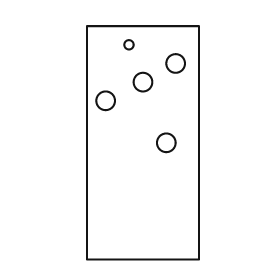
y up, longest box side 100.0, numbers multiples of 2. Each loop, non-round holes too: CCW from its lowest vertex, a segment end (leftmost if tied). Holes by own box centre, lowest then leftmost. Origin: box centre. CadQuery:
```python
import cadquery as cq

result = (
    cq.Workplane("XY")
    .moveTo(-24.0, -50.0)
    .lineTo(24.0, -50.0)
    .lineTo(24.0, 50.0)
    .lineTo(-24.0, 50.0)
    .close()
    .moveTo(10.0, 0.0)
    .circle(4.0)
    .moveTo(-16.0, 18.0)
    .circle(4.0)
    .moveTo(0.0, 26.0)
    .circle(4.0)
    .moveTo(14.0, 34.0)
    .circle(4.0)
    .moveTo(-6.0, 42.0)
    .circle(2.0)
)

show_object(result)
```